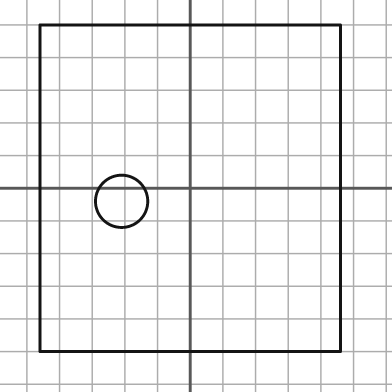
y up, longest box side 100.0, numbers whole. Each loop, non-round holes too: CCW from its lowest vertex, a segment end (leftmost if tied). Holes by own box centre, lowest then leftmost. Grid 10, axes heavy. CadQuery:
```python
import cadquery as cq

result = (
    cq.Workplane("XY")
    .moveTo(-46.0, -50.0)
    .lineTo(46.0, -50.0)
    .lineTo(46.0, 50.0)
    .lineTo(-46.0, 50.0)
    .close()
    .moveTo(-21.0, -4.0)
    .circle(8.0)
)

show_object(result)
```